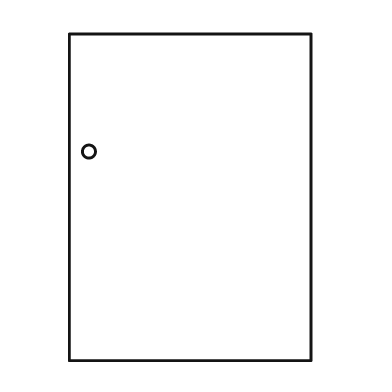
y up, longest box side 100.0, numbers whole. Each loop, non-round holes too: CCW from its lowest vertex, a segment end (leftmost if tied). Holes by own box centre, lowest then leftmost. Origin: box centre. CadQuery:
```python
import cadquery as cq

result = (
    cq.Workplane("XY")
    .moveTo(-37.0, -50.0)
    .lineTo(37.0, -50.0)
    .lineTo(37.0, 50.0)
    .lineTo(-37.0, 50.0)
    .close()
    .moveTo(-31.0, 14.0)
    .circle(2.0)
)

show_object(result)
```